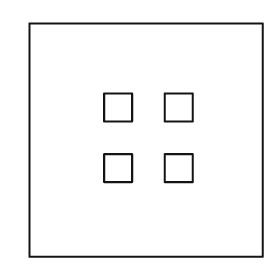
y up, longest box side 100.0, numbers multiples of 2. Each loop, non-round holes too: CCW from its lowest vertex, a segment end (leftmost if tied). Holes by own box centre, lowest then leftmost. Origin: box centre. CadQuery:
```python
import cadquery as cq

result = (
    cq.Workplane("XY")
    .moveTo(-50.0, -50.0)
    .lineTo(50.0, -50.0)
    .lineTo(50.0, 50.0)
    .lineTo(-50.0, 50.0)
    .close()
    .moveTo(-18.0, -18.0)
    .lineTo(-6.0, -18.0)
    .lineTo(-6.0, -6.0)
    .lineTo(-18.0, -6.0)
    .close()
    .moveTo(8.0, -18.0)
    .lineTo(20.0, -18.0)
    .lineTo(20.0, -6.0)
    .lineTo(8.0, -6.0)
    .close()
    .moveTo(-18.0, 8.0)
    .lineTo(-6.0, 8.0)
    .lineTo(-6.0, 20.0)
    .lineTo(-18.0, 20.0)
    .close()
    .moveTo(8.0, 8.0)
    .lineTo(20.0, 8.0)
    .lineTo(20.0, 20.0)
    .lineTo(8.0, 20.0)
    .close()
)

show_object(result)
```